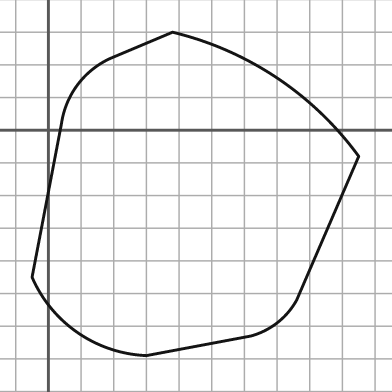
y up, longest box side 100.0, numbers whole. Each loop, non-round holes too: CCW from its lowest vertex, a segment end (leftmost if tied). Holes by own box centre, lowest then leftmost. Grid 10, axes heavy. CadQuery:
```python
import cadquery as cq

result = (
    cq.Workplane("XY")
    .moveTo(30.0, -69.0)
    .lineTo(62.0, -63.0)
    .threePointArc((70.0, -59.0), (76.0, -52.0))
    .lineTo(95.0, -8.0)
    .threePointArc((70.0, 16.0), (38.0, 30.0))
    .lineTo(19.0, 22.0)
    .threePointArc((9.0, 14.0), (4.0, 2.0))
    .lineTo(-5.0, -45.0)
    .threePointArc((9.0, -62.0), (30.0, -69.0))
    .close()
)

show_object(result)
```